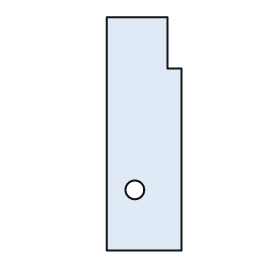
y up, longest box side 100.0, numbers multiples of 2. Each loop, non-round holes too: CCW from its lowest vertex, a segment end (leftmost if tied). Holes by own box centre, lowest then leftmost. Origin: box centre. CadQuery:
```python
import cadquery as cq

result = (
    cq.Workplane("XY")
    .moveTo(-16.0, -50.0)
    .lineTo(16.0, -50.0)
    .lineTo(16.0, 28.0)
    .lineTo(10.0, 28.0)
    .lineTo(10.0, 50.0)
    .lineTo(-16.0, 50.0)
    .close()
    .moveTo(-4.0, -24.0)
    .circle(4.0)
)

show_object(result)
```